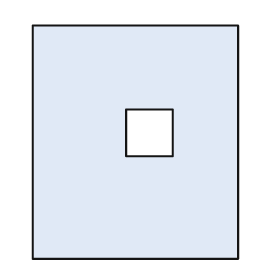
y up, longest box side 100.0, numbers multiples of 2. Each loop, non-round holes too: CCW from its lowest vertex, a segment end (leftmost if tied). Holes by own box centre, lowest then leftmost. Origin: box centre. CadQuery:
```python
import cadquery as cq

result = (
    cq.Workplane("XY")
    .moveTo(-44.0, -50.0)
    .lineTo(44.0, -50.0)
    .lineTo(44.0, 50.0)
    .lineTo(-44.0, 50.0)
    .close()
    .moveTo(-4.0, -6.0)
    .lineTo(16.0, -6.0)
    .lineTo(16.0, 14.0)
    .lineTo(-4.0, 14.0)
    .close()
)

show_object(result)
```